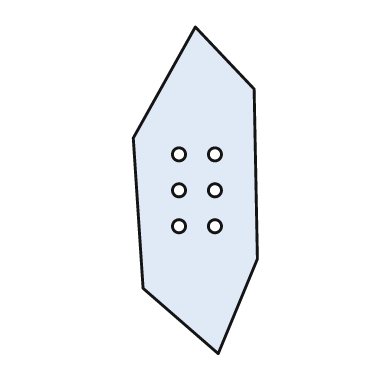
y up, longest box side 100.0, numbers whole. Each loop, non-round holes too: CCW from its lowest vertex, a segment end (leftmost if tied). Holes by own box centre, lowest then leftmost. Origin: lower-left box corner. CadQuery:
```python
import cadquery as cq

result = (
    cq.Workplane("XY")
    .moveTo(26.0, 0.0)
    .lineTo(38.0, 29.0)
    .lineTo(37.0, 81.0)
    .lineTo(19.0, 100.0)
    .lineTo(0.0, 66.0)
    .lineTo(3.0, 20.0)
    .close()
    .moveTo(14.0, 39.0)
    .circle(2.0)
    .moveTo(25.0, 39.0)
    .circle(2.0)
    .moveTo(14.0, 50.0)
    .circle(2.0)
    .moveTo(25.0, 50.0)
    .circle(2.0)
    .moveTo(14.0, 61.0)
    .circle(2.0)
    .moveTo(25.0, 61.0)
    .circle(2.0)
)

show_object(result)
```